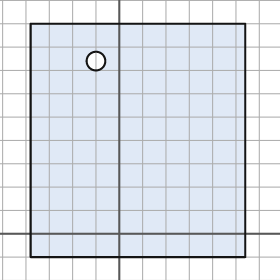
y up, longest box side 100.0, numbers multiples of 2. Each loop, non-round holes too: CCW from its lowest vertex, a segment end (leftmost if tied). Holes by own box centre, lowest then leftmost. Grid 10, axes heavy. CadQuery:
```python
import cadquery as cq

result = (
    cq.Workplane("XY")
    .moveTo(-38.0, -10.0)
    .lineTo(54.0, -10.0)
    .lineTo(54.0, 90.0)
    .lineTo(-38.0, 90.0)
    .close()
    .moveTo(-10.0, 74.0)
    .circle(4.0)
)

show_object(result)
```